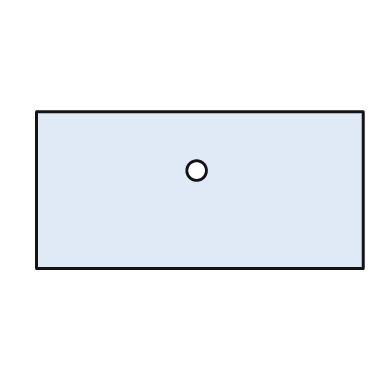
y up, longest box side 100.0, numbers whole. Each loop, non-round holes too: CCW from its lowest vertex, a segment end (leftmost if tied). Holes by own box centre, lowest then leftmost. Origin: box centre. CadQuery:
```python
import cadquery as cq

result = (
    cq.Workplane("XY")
    .moveTo(-50.0, -24.0)
    .lineTo(50.0, -24.0)
    .lineTo(50.0, 24.0)
    .lineTo(-50.0, 24.0)
    .close()
    .moveTo(-1.0, 6.0)
    .circle(3.0)
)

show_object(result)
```